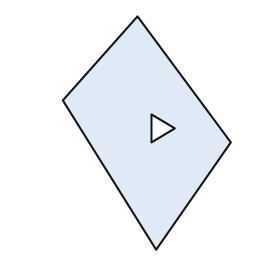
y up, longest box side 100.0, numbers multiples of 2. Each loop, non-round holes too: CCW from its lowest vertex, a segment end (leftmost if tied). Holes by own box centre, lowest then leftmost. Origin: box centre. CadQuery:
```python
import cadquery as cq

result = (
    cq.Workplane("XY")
    .moveTo(4.0, -50.0)
    .lineTo(36.0, -4.0)
    .lineTo(-4.0, 50.0)
    .lineTo(-36.0, 14.0)
    .close()
    .moveTo(2.0, -4.0)
    .lineTo(12.0, 2.0)
    .lineTo(2.0, 8.0)
    .close()
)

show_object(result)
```